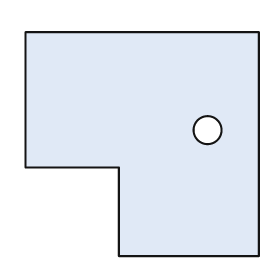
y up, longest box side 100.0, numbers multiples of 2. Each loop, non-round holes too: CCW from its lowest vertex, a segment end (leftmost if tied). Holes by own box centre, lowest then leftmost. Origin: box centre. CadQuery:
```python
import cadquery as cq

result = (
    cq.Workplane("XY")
    .moveTo(-10.0, -48.0)
    .lineTo(50.0, -48.0)
    .lineTo(50.0, 48.0)
    .lineTo(-50.0, 48.0)
    .lineTo(-50.0, -10.0)
    .lineTo(-10.0, -10.0)
    .close()
    .moveTo(28.0, 6.0)
    .circle(6.0)
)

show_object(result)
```